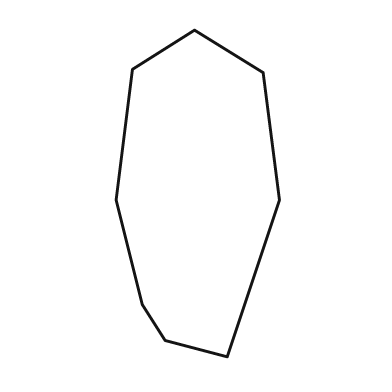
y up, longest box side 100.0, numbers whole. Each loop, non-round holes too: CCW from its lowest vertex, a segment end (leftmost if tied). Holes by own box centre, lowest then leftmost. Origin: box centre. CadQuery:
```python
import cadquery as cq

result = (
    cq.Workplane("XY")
    .moveTo(9.0, -50.0)
    .lineTo(25.0, -2.0)
    .lineTo(20.0, 37.0)
    .lineTo(-1.0, 50.0)
    .lineTo(-20.0, 38.0)
    .lineTo(-25.0, -2.0)
    .lineTo(-17.0, -34.0)
    .lineTo(-10.0, -45.0)
    .close()
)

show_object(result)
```